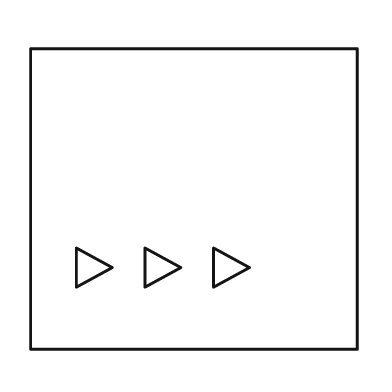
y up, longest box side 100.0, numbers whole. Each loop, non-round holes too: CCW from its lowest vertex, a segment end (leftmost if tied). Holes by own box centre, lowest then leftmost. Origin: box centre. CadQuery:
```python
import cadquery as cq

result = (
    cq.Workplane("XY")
    .moveTo(-50.0, -46.0)
    .lineTo(50.0, -46.0)
    .lineTo(50.0, 46.0)
    .lineTo(-50.0, 46.0)
    .close()
    .moveTo(-36.0, -27.0)
    .lineTo(-25.0, -21.0)
    .lineTo(-36.0, -15.0)
    .close()
    .moveTo(-15.0, -27.0)
    .lineTo(-4.0, -21.0)
    .lineTo(-15.0, -15.0)
    .close()
    .moveTo(6.0, -27.0)
    .lineTo(17.0, -21.0)
    .lineTo(6.0, -15.0)
    .close()
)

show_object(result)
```